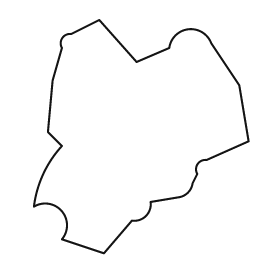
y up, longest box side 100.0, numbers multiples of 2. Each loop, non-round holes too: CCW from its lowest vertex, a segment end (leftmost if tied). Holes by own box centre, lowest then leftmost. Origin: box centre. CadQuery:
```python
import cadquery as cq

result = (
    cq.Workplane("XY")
    .moveTo(-16.0, -50.0)
    .lineTo(-4.0, -36.0)
    .threePointArc((2.0, -34.0), (4.0, -28.0))
    .lineTo(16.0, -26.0)
    .threePointArc((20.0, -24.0), (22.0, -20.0))
    .lineTo(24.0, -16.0)
    .threePointArc((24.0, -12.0), (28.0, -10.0))
    .lineTo(46.0, -2.0)
    .lineTo(42.0, 22.0)
    .lineTo(30.0, 40.0)
    .threePointArc((20.0, 46.0), (12.0, 38.0))
    .lineTo(-2.0, 32.0)
    .lineTo(-18.0, 50.0)
    .lineTo(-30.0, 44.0)
    .threePointArc((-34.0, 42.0), (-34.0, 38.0))
    .lineTo(-38.0, 24.0)
    .lineTo(-40.0, 2.0)
    .lineTo(-34.0, -4.0)
    .threePointArc((-42.0, -16.0), (-46.0, -30.0))
    .threePointArc((-34.0, -32.0), (-34.0, -44.0))
    .close()
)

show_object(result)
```